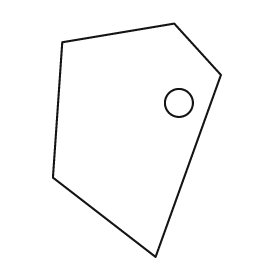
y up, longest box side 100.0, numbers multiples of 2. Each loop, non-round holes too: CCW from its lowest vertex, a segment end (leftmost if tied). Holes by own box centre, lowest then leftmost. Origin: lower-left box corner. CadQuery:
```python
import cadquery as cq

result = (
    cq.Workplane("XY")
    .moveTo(44.0, 0.0)
    .lineTo(72.0, 78.0)
    .lineTo(52.0, 100.0)
    .lineTo(4.0, 92.0)
    .lineTo(0.0, 34.0)
    .close()
    .moveTo(54.0, 66.0)
    .circle(6.0)
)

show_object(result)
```